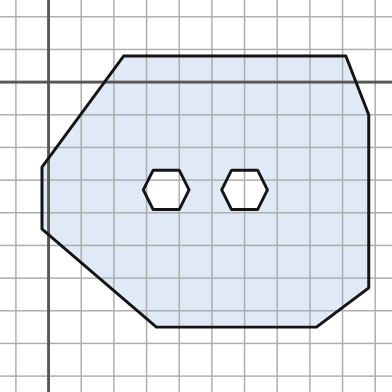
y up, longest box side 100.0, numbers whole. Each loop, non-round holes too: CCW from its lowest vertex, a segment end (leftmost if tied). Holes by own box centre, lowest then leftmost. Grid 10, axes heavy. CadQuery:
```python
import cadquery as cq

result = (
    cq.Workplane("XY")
    .moveTo(33.0, -75.0)
    .lineTo(82.0, -75.0)
    .lineTo(98.0, -63.0)
    .lineTo(98.0, -10.0)
    .lineTo(91.0, 8.0)
    .lineTo(23.0, 8.0)
    .lineTo(-2.0, -26.0)
    .lineTo(-2.0, -45.0)
    .close()
    .moveTo(32.0, -39.0)
    .lineTo(40.0, -39.0)
    .lineTo(43.0, -33.0)
    .lineTo(40.0, -27.0)
    .lineTo(32.0, -27.0)
    .lineTo(29.0, -33.0)
    .close()
    .moveTo(56.0, -39.0)
    .lineTo(64.0, -39.0)
    .lineTo(67.0, -33.0)
    .lineTo(64.0, -27.0)
    .lineTo(56.0, -27.0)
    .lineTo(53.0, -33.0)
    .close()
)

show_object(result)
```